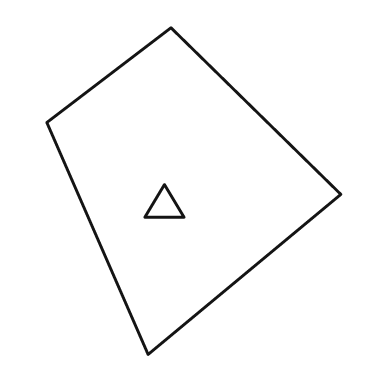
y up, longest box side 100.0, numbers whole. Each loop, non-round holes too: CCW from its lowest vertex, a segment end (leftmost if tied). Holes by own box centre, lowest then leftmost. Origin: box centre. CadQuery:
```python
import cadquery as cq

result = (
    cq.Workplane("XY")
    .moveTo(-14.0, -50.0)
    .lineTo(45.0, -1.0)
    .lineTo(-7.0, 50.0)
    .lineTo(-45.0, 21.0)
    .close()
    .moveTo(-15.0, -8.0)
    .lineTo(-3.0, -8.0)
    .lineTo(-9.0, 2.0)
    .close()
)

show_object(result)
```